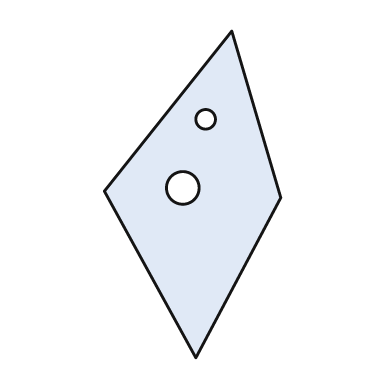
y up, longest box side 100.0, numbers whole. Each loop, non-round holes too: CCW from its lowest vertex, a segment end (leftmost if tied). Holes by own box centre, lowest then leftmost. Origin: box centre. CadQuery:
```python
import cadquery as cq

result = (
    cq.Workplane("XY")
    .moveTo(1.0, -50.0)
    .lineTo(27.0, -1.0)
    .lineTo(12.0, 50.0)
    .lineTo(-27.0, 1.0)
    .close()
    .moveTo(-3.0, 2.0)
    .circle(5.0)
    .moveTo(4.0, 23.0)
    .circle(3.0)
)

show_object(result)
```